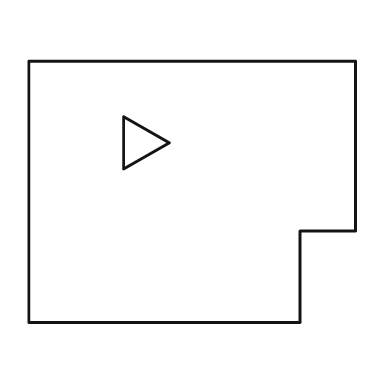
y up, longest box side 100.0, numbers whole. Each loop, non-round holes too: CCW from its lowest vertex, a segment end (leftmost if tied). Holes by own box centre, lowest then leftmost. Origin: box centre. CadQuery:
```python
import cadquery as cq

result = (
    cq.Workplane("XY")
    .moveTo(-50.0, -40.0)
    .lineTo(33.0, -40.0)
    .lineTo(33.0, -12.0)
    .lineTo(50.0, -12.0)
    .lineTo(50.0, 40.0)
    .lineTo(-50.0, 40.0)
    .close()
    .moveTo(-21.0, 7.0)
    .lineTo(-7.0, 15.0)
    .lineTo(-21.0, 23.0)
    .close()
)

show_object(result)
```